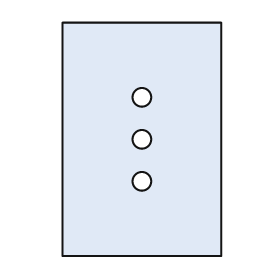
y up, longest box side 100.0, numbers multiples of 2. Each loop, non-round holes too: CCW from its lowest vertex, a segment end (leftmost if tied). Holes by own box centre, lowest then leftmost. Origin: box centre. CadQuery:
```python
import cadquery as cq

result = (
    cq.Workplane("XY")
    .moveTo(-34.0, -50.0)
    .lineTo(34.0, -50.0)
    .lineTo(34.0, 50.0)
    .lineTo(-34.0, 50.0)
    .close()
    .moveTo(0.0, -18.0)
    .circle(4.0)
    .moveTo(0.0, 0.0)
    .circle(4.0)
    .moveTo(0.0, 18.0)
    .circle(4.0)
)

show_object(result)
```